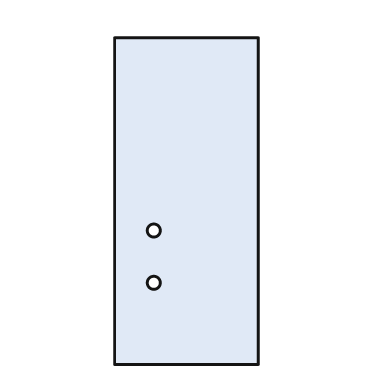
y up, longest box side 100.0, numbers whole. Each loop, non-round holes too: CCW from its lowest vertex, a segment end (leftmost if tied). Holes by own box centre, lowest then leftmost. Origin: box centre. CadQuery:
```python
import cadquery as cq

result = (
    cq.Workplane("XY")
    .moveTo(-22.0, -50.0)
    .lineTo(22.0, -50.0)
    .lineTo(22.0, 50.0)
    .lineTo(-22.0, 50.0)
    .close()
    .moveTo(-10.0, -25.0)
    .circle(2.0)
    .moveTo(-10.0, -9.0)
    .circle(2.0)
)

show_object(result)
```